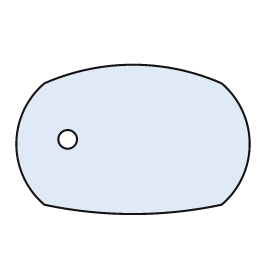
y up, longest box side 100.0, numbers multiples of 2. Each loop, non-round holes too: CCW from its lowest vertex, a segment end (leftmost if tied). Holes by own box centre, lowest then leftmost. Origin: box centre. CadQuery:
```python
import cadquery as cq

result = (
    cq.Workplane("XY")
    .moveTo(-38.0, -28.0)
    .threePointArc((0.0, -32.0), (38.0, -28.0))
    .threePointArc((50.0, -2.0), (38.0, 24.0))
    .threePointArc((0.0, 32.0), (-38.0, 24.0))
    .threePointArc((-50.0, -2.0), (-38.0, -28.0))
    .close()
    .moveTo(-28.0, 0.0)
    .circle(4.0)
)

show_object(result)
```